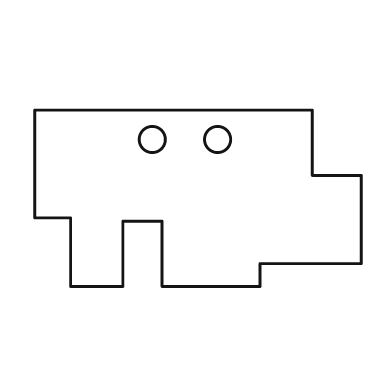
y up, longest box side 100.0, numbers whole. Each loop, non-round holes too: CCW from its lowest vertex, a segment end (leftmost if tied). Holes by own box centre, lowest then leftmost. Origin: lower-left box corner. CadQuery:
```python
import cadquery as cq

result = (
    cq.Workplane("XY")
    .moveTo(11.0, 0.0)
    .lineTo(27.0, 0.0)
    .lineTo(27.0, 20.0)
    .lineTo(39.0, 20.0)
    .lineTo(39.0, 0.0)
    .lineTo(69.0, 0.0)
    .lineTo(69.0, 7.0)
    .lineTo(100.0, 7.0)
    .lineTo(100.0, 34.0)
    .lineTo(85.0, 34.0)
    .lineTo(85.0, 54.0)
    .lineTo(0.0, 54.0)
    .lineTo(0.0, 21.0)
    .lineTo(11.0, 21.0)
    .close()
    .moveTo(36.0, 45.0)
    .circle(4.0)
    .moveTo(56.0, 45.0)
    .circle(4.0)
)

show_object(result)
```